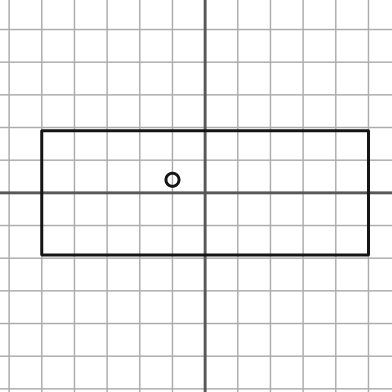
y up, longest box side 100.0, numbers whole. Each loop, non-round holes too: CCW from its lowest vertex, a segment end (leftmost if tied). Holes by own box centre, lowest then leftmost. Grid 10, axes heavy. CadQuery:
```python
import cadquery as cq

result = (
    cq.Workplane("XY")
    .moveTo(-50.0, -19.0)
    .lineTo(50.0, -19.0)
    .lineTo(50.0, 19.0)
    .lineTo(-50.0, 19.0)
    .close()
    .moveTo(-10.0, 4.0)
    .circle(2.0)
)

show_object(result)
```